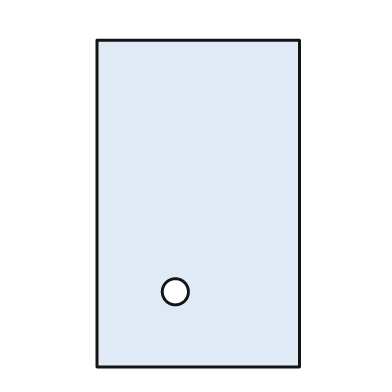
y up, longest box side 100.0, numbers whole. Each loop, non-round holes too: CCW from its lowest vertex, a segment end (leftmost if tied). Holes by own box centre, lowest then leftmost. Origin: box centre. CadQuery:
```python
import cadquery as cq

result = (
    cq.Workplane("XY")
    .moveTo(-31.0, -50.0)
    .lineTo(31.0, -50.0)
    .lineTo(31.0, 50.0)
    .lineTo(-31.0, 50.0)
    .close()
    .moveTo(-7.0, -27.0)
    .circle(4.0)
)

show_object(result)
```